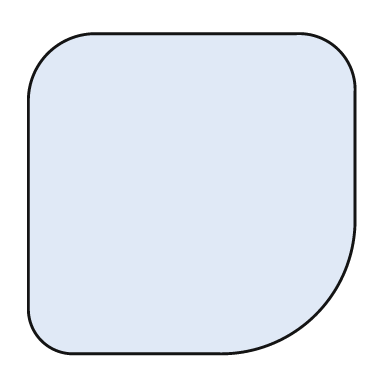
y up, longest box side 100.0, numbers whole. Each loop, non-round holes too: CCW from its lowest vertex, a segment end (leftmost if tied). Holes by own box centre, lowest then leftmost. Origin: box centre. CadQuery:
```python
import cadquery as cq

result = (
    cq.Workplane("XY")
    .moveTo(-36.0, -49.0)
    .lineTo(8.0, -49.0)
    .threePointArc((38.0, -37.0), (50.0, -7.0))
    .lineTo(50.0, 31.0)
    .threePointArc((45.0, 44.0), (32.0, 49.0))
    .lineTo(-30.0, 49.0)
    .threePointArc((-44.0, 43.0), (-50.0, 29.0))
    .lineTo(-50.0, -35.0)
    .threePointArc((-46.0, -45.0), (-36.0, -49.0))
    .close()
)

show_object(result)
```